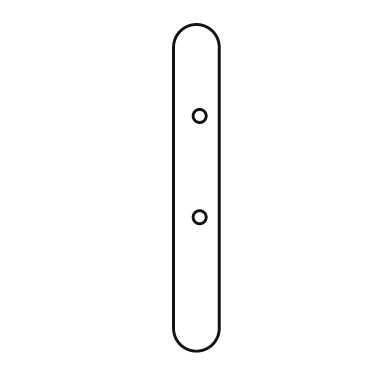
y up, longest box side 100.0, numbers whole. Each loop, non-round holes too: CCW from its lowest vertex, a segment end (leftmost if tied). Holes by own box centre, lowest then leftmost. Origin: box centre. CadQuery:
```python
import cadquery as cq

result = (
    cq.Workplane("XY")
    .moveTo(-7.0, -43.0)
    .threePointArc((0.0, -50.0), (7.0, -43.0))
    .lineTo(7.0, 43.0)
    .threePointArc((0.0, 50.0), (-7.0, 43.0))
    .close()
    .moveTo(1.0, -9.0)
    .circle(2.0)
    .moveTo(1.0, 22.0)
    .circle(2.0)
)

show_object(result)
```